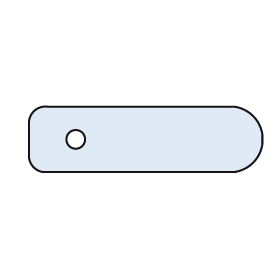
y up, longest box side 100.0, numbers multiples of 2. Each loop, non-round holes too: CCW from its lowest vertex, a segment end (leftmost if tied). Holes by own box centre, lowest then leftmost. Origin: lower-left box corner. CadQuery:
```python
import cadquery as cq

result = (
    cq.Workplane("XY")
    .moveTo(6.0, 0.0)
    .lineTo(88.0, 0.0)
    .threePointArc((96.0, 4.0), (100.0, 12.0))
    .lineTo(100.0, 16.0)
    .threePointArc((96.0, 24.0), (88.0, 28.0))
    .lineTo(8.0, 28.0)
    .threePointArc((2.0, 26.0), (0.0, 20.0))
    .lineTo(0.0, 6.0)
    .threePointArc((2.0, 2.0), (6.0, 0.0))
    .close()
    .moveTo(20.0, 14.0)
    .circle(4.0)
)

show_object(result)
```